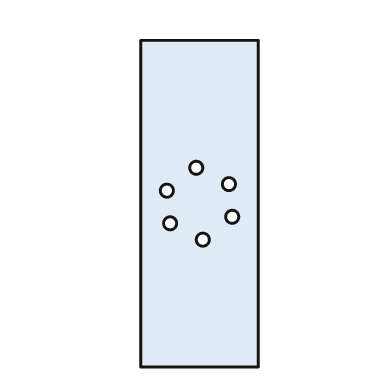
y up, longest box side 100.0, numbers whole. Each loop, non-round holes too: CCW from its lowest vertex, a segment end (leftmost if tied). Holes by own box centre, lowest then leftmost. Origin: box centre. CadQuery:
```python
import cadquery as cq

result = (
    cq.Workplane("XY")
    .moveTo(-18.0, -50.0)
    .lineTo(18.0, -50.0)
    .lineTo(18.0, 50.0)
    .lineTo(-18.0, 50.0)
    .close()
    .moveTo(1.0, -11.0)
    .circle(2.0)
    .moveTo(-9.0, -6.0)
    .circle(2.0)
    .moveTo(10.0, -4.0)
    .circle(2.0)
    .moveTo(-10.0, 4.0)
    .circle(2.0)
    .moveTo(9.0, 6.0)
    .circle(2.0)
    .moveTo(-1.0, 11.0)
    .circle(2.0)
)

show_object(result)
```